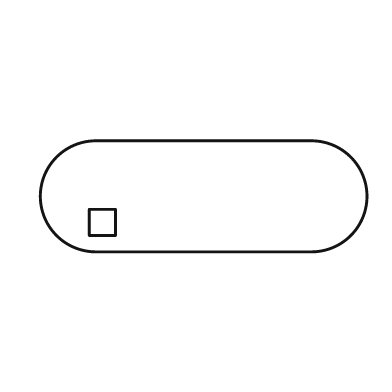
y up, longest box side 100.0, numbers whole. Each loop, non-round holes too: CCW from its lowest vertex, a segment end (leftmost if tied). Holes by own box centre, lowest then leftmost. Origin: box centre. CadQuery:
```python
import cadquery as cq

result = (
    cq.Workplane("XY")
    .moveTo(-33.0, -17.0)
    .lineTo(33.0, -17.0)
    .threePointArc((50.0, 0.0), (33.0, 17.0))
    .lineTo(-33.0, 17.0)
    .threePointArc((-50.0, 0.0), (-33.0, -17.0))
    .close()
    .moveTo(-35.0, -12.0)
    .lineTo(-27.0, -12.0)
    .lineTo(-27.0, -4.0)
    .lineTo(-35.0, -4.0)
    .close()
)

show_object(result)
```